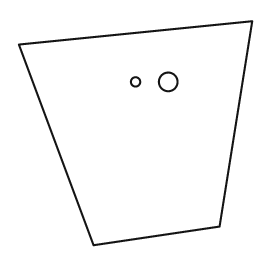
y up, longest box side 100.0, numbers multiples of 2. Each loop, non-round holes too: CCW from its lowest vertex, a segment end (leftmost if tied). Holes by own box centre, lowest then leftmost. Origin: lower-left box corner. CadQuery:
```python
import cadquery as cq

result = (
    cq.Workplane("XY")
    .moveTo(32.0, 0.0)
    .lineTo(86.0, 8.0)
    .lineTo(100.0, 96.0)
    .lineTo(0.0, 86.0)
    .close()
    .moveTo(50.0, 70.0)
    .circle(2.0)
    .moveTo(64.0, 70.0)
    .circle(4.0)
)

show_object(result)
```